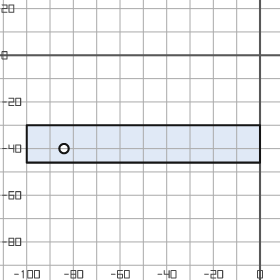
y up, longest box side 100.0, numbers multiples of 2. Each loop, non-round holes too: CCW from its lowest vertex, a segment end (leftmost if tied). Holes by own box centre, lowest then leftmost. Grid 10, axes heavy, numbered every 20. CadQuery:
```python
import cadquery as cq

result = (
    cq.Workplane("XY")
    .moveTo(-100.0, -46.0)
    .lineTo(0.0, -46.0)
    .lineTo(0.0, -30.0)
    .lineTo(-100.0, -30.0)
    .close()
    .moveTo(-84.0, -40.0)
    .circle(2.0)
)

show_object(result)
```